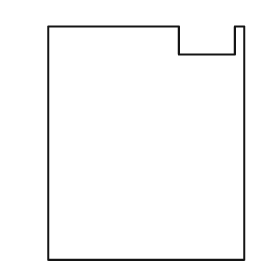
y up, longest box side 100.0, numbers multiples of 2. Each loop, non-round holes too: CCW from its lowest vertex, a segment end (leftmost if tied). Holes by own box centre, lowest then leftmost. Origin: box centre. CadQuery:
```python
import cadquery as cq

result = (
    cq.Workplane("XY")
    .moveTo(-42.0, -50.0)
    .lineTo(42.0, -50.0)
    .lineTo(42.0, 50.0)
    .lineTo(38.0, 50.0)
    .lineTo(38.0, 38.0)
    .lineTo(14.0, 38.0)
    .lineTo(14.0, 50.0)
    .lineTo(-42.0, 50.0)
    .close()
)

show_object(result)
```